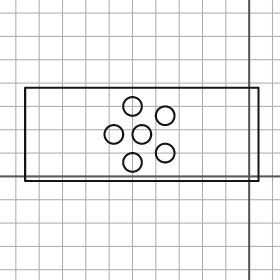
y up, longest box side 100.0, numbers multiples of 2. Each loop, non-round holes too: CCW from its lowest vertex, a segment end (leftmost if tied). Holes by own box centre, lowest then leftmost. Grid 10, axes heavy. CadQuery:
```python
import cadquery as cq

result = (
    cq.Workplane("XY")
    .moveTo(-96.0, -2.0)
    .lineTo(4.0, -2.0)
    .lineTo(4.0, 38.0)
    .lineTo(-96.0, 38.0)
    .close()
    .moveTo(-50.0, 6.0)
    .circle(4.0)
    .moveTo(-36.0, 10.0)
    .circle(4.0)
    .moveTo(-58.0, 18.0)
    .circle(4.0)
    .moveTo(-46.0, 18.0)
    .circle(4.0)
    .moveTo(-36.0, 26.0)
    .circle(4.0)
    .moveTo(-50.0, 30.0)
    .circle(4.0)
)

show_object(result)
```